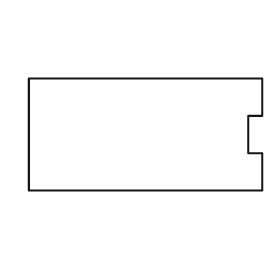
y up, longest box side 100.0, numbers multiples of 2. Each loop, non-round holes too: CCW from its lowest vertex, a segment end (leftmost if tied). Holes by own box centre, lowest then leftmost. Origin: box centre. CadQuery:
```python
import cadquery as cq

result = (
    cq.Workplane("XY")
    .moveTo(-50.0, -24.0)
    .lineTo(50.0, -24.0)
    .lineTo(50.0, -8.0)
    .lineTo(44.0, -8.0)
    .lineTo(44.0, 8.0)
    .lineTo(50.0, 8.0)
    .lineTo(50.0, 24.0)
    .lineTo(-50.0, 24.0)
    .close()
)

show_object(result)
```